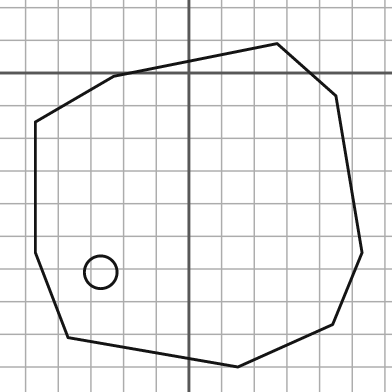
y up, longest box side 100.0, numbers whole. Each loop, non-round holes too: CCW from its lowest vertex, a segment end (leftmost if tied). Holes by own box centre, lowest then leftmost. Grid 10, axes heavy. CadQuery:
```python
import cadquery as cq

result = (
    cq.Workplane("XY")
    .moveTo(15.0, -90.0)
    .lineTo(44.0, -77.0)
    .lineTo(53.0, -55.0)
    .lineTo(45.0, -7.0)
    .lineTo(27.0, 9.0)
    .lineTo(-23.0, -1.0)
    .lineTo(-47.0, -15.0)
    .lineTo(-47.0, -55.0)
    .lineTo(-37.0, -81.0)
    .close()
    .moveTo(-27.0, -61.0)
    .circle(5.0)
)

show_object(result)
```